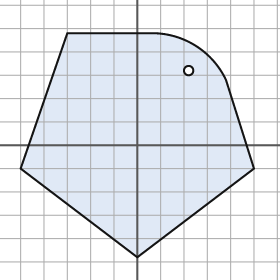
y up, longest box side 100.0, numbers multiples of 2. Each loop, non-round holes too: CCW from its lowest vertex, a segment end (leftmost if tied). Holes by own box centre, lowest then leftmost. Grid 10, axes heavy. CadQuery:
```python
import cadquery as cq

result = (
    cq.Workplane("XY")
    .moveTo(0.0, -48.0)
    .lineTo(50.0, -10.0)
    .lineTo(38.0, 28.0)
    .threePointArc((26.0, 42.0), (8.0, 48.0))
    .lineTo(-30.0, 48.0)
    .lineTo(-50.0, -10.0)
    .close()
    .moveTo(22.0, 32.0)
    .circle(2.0)
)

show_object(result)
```